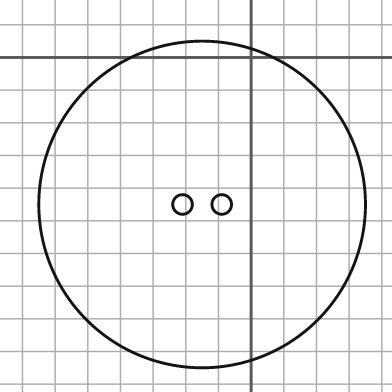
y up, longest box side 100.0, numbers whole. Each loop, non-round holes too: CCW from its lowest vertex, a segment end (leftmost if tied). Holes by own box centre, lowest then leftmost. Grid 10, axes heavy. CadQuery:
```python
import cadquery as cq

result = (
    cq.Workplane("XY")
    .moveTo(-15.0, -45.0)
    .circle(50.0)
    .moveTo(-21.0, -45.0)
    .circle(3.0)
    .moveTo(-9.0, -45.0)
    .circle(3.0)
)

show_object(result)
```